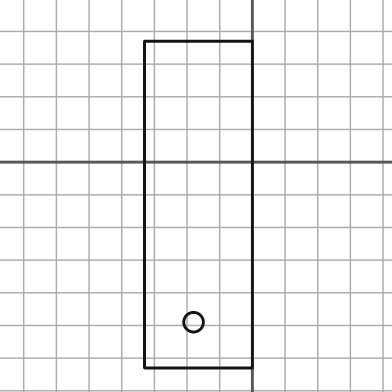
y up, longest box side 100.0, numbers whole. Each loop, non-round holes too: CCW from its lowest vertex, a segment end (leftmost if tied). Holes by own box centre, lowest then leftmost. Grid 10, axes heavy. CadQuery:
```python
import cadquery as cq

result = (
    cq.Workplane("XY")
    .moveTo(-33.0, -63.0)
    .lineTo(0.0, -63.0)
    .lineTo(0.0, 37.0)
    .lineTo(-33.0, 37.0)
    .close()
    .moveTo(-18.0, -49.0)
    .circle(3.0)
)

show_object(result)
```